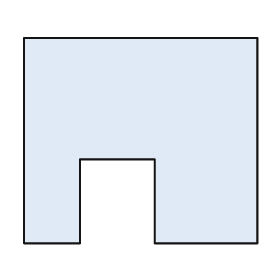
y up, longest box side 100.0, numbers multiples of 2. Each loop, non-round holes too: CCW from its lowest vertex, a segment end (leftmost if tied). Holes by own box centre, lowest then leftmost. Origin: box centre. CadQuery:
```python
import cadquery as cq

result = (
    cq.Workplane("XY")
    .moveTo(-50.0, -44.0)
    .lineTo(-26.0, -44.0)
    .lineTo(-26.0, -8.0)
    .lineTo(6.0, -8.0)
    .lineTo(6.0, -44.0)
    .lineTo(50.0, -44.0)
    .lineTo(50.0, 44.0)
    .lineTo(-50.0, 44.0)
    .close()
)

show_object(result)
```